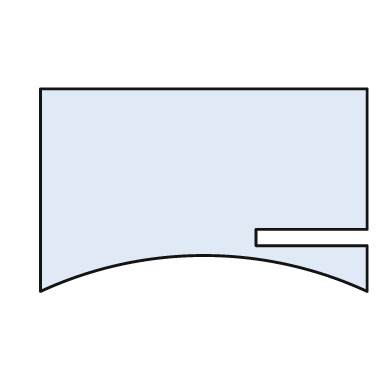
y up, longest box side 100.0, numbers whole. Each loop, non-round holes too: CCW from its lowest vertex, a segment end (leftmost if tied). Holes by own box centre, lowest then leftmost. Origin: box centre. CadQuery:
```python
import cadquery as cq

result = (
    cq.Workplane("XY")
    .moveTo(-50.0, -31.0)
    .threePointArc((0.0, -20.0), (50.0, -31.0))
    .lineTo(50.0, -17.0)
    .lineTo(16.0, -17.0)
    .lineTo(16.0, -12.0)
    .lineTo(50.0, -12.0)
    .lineTo(50.0, 31.0)
    .lineTo(-50.0, 31.0)
    .close()
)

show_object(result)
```